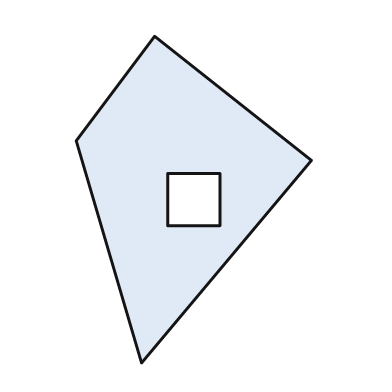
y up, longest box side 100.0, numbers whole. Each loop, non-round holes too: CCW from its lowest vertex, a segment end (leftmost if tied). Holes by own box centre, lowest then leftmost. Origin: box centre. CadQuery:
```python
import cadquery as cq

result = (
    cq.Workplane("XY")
    .moveTo(-16.0, -50.0)
    .lineTo(36.0, 12.0)
    .lineTo(-12.0, 50.0)
    .lineTo(-36.0, 18.0)
    .close()
    .moveTo(-8.0, -8.0)
    .lineTo(8.0, -8.0)
    .lineTo(8.0, 8.0)
    .lineTo(-8.0, 8.0)
    .close()
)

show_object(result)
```